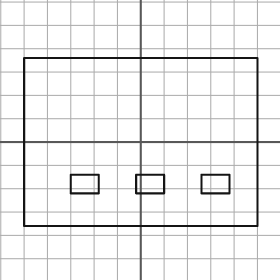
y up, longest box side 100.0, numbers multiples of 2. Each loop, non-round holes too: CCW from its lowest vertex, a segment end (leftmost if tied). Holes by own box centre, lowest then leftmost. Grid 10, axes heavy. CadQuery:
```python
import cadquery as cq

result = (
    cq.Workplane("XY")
    .moveTo(-50.0, -36.0)
    .lineTo(50.0, -36.0)
    .lineTo(50.0, 36.0)
    .lineTo(-50.0, 36.0)
    .close()
    .moveTo(-30.0, -22.0)
    .lineTo(-18.0, -22.0)
    .lineTo(-18.0, -14.0)
    .lineTo(-30.0, -14.0)
    .close()
    .moveTo(-2.0, -22.0)
    .lineTo(10.0, -22.0)
    .lineTo(10.0, -14.0)
    .lineTo(-2.0, -14.0)
    .close()
    .moveTo(26.0, -22.0)
    .lineTo(38.0, -22.0)
    .lineTo(38.0, -14.0)
    .lineTo(26.0, -14.0)
    .close()
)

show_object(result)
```